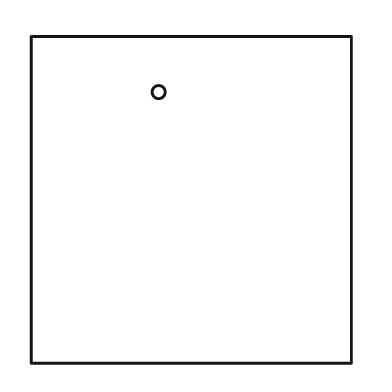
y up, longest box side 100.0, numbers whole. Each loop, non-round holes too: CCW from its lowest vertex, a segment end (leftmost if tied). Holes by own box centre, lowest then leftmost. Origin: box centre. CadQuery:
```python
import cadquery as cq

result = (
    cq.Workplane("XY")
    .moveTo(-49.0, -50.0)
    .lineTo(49.0, -50.0)
    .lineTo(49.0, 50.0)
    .lineTo(-49.0, 50.0)
    .close()
    .moveTo(-10.0, 33.0)
    .circle(2.0)
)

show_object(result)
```